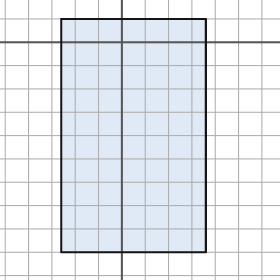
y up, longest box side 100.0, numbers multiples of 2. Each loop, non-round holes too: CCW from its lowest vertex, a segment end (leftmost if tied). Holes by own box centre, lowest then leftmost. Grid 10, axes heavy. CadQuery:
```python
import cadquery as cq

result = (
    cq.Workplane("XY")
    .moveTo(-26.0, -90.0)
    .lineTo(36.0, -90.0)
    .lineTo(36.0, 10.0)
    .lineTo(-26.0, 10.0)
    .close()
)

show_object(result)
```